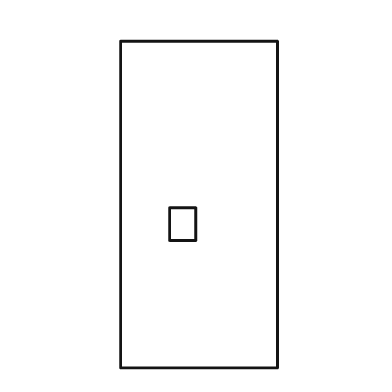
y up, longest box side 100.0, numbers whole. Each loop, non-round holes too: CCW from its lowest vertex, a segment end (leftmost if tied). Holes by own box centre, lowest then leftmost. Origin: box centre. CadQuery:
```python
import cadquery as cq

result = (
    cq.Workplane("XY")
    .moveTo(-24.0, -50.0)
    .lineTo(24.0, -50.0)
    .lineTo(24.0, 50.0)
    .lineTo(-24.0, 50.0)
    .close()
    .moveTo(-9.0, -11.0)
    .lineTo(-1.0, -11.0)
    .lineTo(-1.0, -1.0)
    .lineTo(-9.0, -1.0)
    .close()
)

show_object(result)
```